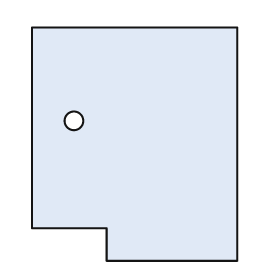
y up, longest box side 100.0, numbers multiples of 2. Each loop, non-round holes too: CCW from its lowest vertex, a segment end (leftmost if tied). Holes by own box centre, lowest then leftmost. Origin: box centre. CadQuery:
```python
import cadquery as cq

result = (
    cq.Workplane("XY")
    .moveTo(-12.0, -50.0)
    .lineTo(44.0, -50.0)
    .lineTo(44.0, 50.0)
    .lineTo(-44.0, 50.0)
    .lineTo(-44.0, -36.0)
    .lineTo(-12.0, -36.0)
    .close()
    .moveTo(-26.0, 10.0)
    .circle(4.0)
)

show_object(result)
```